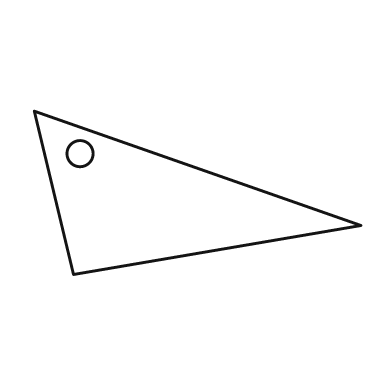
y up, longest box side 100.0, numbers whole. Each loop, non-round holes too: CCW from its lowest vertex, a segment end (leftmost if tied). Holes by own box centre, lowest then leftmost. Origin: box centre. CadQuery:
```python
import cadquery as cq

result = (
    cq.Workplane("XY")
    .moveTo(-38.0, -25.0)
    .lineTo(50.0, -10.0)
    .lineTo(-50.0, 25.0)
    .close()
    .moveTo(-36.0, 12.0)
    .circle(4.0)
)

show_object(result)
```